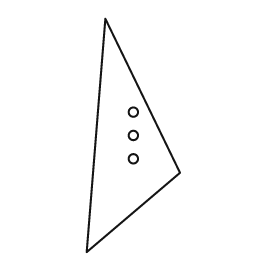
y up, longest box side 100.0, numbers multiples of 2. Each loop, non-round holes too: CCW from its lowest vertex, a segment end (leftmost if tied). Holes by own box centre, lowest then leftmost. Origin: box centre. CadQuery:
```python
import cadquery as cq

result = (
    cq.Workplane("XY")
    .moveTo(-20.0, -50.0)
    .lineTo(20.0, -16.0)
    .lineTo(-12.0, 50.0)
    .close()
    .moveTo(0.0, -10.0)
    .circle(2.0)
    .moveTo(0.0, 0.0)
    .circle(2.0)
    .moveTo(0.0, 10.0)
    .circle(2.0)
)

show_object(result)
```